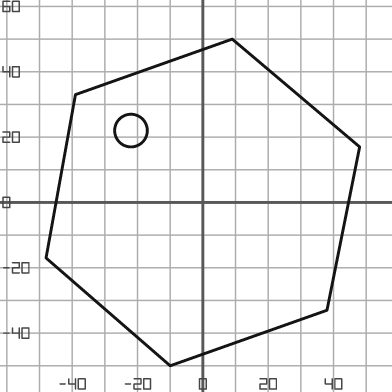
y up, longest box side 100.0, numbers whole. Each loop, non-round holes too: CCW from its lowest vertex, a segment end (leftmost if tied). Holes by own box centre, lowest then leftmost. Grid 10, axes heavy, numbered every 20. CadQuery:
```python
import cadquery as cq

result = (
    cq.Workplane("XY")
    .moveTo(-10.0, -50.0)
    .lineTo(38.0, -33.0)
    .lineTo(48.0, 17.0)
    .lineTo(9.0, 50.0)
    .lineTo(-39.0, 33.0)
    .lineTo(-48.0, -17.0)
    .close()
    .moveTo(-22.0, 22.0)
    .circle(5.0)
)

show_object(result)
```